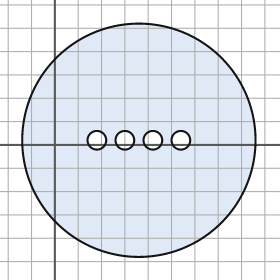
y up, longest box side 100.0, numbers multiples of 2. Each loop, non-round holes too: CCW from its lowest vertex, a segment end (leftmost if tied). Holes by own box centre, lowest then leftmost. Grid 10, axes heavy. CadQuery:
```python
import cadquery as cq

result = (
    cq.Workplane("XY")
    .moveTo(36.0, 2.0)
    .circle(50.0)
    .moveTo(18.0, 2.0)
    .circle(4.0)
    .moveTo(30.0, 2.0)
    .circle(4.0)
    .moveTo(42.0, 2.0)
    .circle(4.0)
    .moveTo(54.0, 2.0)
    .circle(4.0)
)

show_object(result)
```